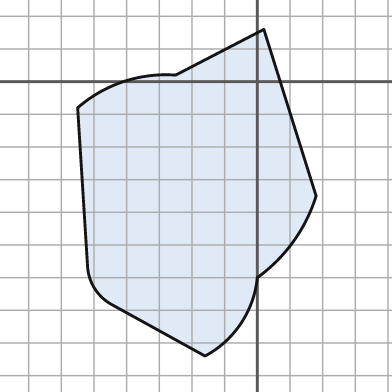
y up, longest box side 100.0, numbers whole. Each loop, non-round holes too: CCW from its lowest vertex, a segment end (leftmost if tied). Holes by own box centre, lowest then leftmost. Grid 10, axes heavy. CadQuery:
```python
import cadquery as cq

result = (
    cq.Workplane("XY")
    .moveTo(-16.0, -84.0)
    .threePointArc((-5.0, -74.0), (0.0, -60.0))
    .threePointArc((11.0, -49.0), (18.0, -35.0))
    .lineTo(2.0, 16.0)
    .lineTo(-25.0, 2.0)
    .threePointArc((-41.0, 0.0), (-55.0, -8.0))
    .lineTo(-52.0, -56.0)
    .threePointArc((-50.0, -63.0), (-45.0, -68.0))
    .close()
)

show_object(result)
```